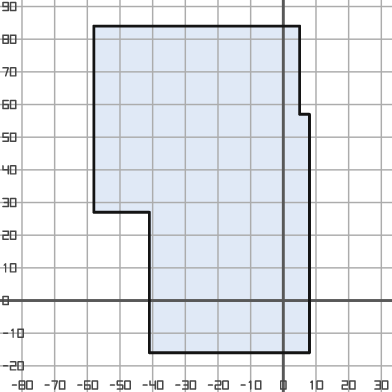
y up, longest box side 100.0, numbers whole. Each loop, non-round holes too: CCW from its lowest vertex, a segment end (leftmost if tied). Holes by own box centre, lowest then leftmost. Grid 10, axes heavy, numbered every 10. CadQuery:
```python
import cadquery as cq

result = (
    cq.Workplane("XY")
    .moveTo(-41.0, -16.0)
    .lineTo(8.0, -16.0)
    .lineTo(8.0, 57.0)
    .lineTo(5.0, 57.0)
    .lineTo(5.0, 84.0)
    .lineTo(-58.0, 84.0)
    .lineTo(-58.0, 27.0)
    .lineTo(-41.0, 27.0)
    .close()
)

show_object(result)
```